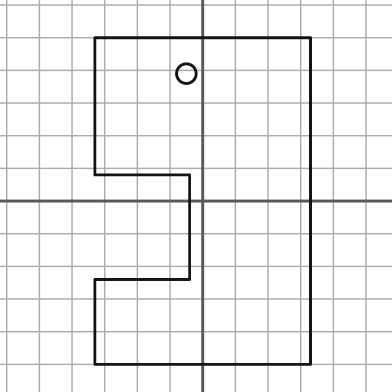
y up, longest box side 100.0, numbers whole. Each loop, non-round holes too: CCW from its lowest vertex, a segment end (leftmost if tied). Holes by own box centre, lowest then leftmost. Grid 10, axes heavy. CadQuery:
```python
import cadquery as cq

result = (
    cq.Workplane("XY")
    .moveTo(-33.0, -50.0)
    .lineTo(33.0, -50.0)
    .lineTo(33.0, 50.0)
    .lineTo(-33.0, 50.0)
    .lineTo(-33.0, 8.0)
    .lineTo(-4.0, 8.0)
    .lineTo(-4.0, -24.0)
    .lineTo(-33.0, -24.0)
    .close()
    .moveTo(-5.0, 39.0)
    .circle(3.0)
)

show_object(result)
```